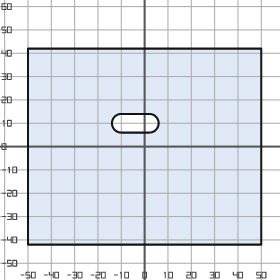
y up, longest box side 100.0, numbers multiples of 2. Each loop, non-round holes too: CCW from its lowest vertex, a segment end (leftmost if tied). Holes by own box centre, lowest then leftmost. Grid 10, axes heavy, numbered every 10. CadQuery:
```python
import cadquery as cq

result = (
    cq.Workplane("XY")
    .moveTo(-50.0, -42.0)
    .lineTo(50.0, -42.0)
    .lineTo(50.0, 42.0)
    .lineTo(-50.0, 42.0)
    .close()
    .moveTo(-10.0, 6.0)
    .lineTo(2.0, 6.0)
    .threePointArc((6.0, 10.0), (2.0, 14.0))
    .lineTo(-10.0, 14.0)
    .threePointArc((-14.0, 10.0), (-10.0, 6.0))
    .close()
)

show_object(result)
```